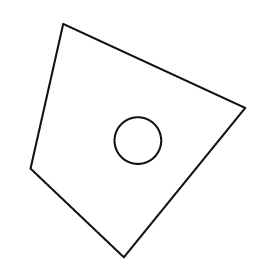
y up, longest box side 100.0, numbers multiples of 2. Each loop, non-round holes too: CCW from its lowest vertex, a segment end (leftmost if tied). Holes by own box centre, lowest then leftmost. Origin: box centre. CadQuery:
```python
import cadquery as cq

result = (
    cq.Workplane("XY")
    .moveTo(-6.0, -50.0)
    .lineTo(46.0, 14.0)
    .lineTo(-32.0, 50.0)
    .lineTo(-46.0, -12.0)
    .close()
    .moveTo(0.0, 0.0)
    .circle(10.0)
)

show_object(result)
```